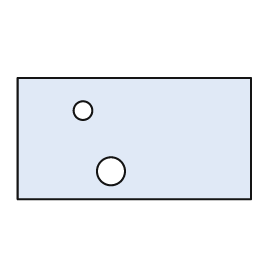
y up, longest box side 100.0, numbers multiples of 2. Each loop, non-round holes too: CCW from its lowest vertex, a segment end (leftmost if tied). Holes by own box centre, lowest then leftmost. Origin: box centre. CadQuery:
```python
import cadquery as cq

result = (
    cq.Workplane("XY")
    .moveTo(-50.0, -26.0)
    .lineTo(50.0, -26.0)
    .lineTo(50.0, 26.0)
    .lineTo(-50.0, 26.0)
    .close()
    .moveTo(-10.0, -14.0)
    .circle(6.0)
    .moveTo(-22.0, 12.0)
    .circle(4.0)
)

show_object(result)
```